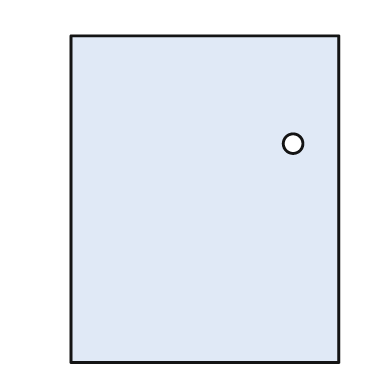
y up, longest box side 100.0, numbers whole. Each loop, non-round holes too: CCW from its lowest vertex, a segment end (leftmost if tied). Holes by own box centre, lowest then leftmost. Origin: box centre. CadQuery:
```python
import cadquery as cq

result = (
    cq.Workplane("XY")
    .moveTo(-41.0, -50.0)
    .lineTo(41.0, -50.0)
    .lineTo(41.0, 50.0)
    .lineTo(-41.0, 50.0)
    .close()
    .moveTo(27.0, 17.0)
    .circle(3.0)
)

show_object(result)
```